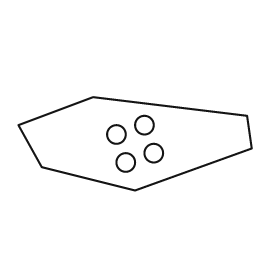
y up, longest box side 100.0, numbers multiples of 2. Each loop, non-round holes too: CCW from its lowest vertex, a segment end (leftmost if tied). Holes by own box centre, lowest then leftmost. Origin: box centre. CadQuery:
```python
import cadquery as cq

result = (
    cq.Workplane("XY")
    .moveTo(0.0, -20.0)
    .lineTo(50.0, -2.0)
    .lineTo(48.0, 12.0)
    .lineTo(-18.0, 20.0)
    .lineTo(-50.0, 8.0)
    .lineTo(-40.0, -10.0)
    .close()
    .moveTo(-4.0, -8.0)
    .circle(4.0)
    .moveTo(8.0, -4.0)
    .circle(4.0)
    .moveTo(-8.0, 4.0)
    .circle(4.0)
    .moveTo(4.0, 8.0)
    .circle(4.0)
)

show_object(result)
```